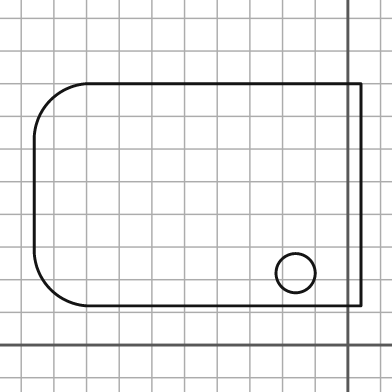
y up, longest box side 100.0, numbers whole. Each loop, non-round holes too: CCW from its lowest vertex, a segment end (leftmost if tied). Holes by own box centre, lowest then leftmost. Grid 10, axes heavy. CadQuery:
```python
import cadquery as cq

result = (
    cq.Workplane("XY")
    .moveTo(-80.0, 12.0)
    .lineTo(4.0, 12.0)
    .lineTo(4.0, 80.0)
    .lineTo(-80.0, 80.0)
    .threePointArc((-91.0, 75.0), (-96.0, 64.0))
    .lineTo(-96.0, 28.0)
    .threePointArc((-91.0, 17.0), (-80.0, 12.0))
    .close()
    .moveTo(-16.0, 22.0)
    .circle(6.0)
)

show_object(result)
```